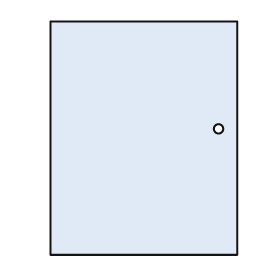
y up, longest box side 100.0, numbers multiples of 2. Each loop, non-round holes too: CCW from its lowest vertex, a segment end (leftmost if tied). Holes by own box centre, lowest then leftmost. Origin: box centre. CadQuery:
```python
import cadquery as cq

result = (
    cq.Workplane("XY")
    .moveTo(-40.0, -50.0)
    .lineTo(40.0, -50.0)
    .lineTo(40.0, 50.0)
    .lineTo(-40.0, 50.0)
    .close()
    .moveTo(32.0, 4.0)
    .circle(2.0)
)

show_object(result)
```